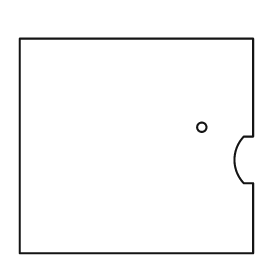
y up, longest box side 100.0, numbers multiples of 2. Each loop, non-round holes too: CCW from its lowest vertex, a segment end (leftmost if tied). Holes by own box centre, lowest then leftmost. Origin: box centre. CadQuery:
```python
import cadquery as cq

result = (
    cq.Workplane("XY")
    .moveTo(-50.0, -46.0)
    .lineTo(50.0, -46.0)
    .lineTo(50.0, -16.0)
    .lineTo(46.0, -16.0)
    .threePointArc((42.0, -6.0), (46.0, 4.0))
    .lineTo(50.0, 4.0)
    .lineTo(50.0, 46.0)
    .lineTo(-50.0, 46.0)
    .close()
    .moveTo(28.0, 8.0)
    .circle(2.0)
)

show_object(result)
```